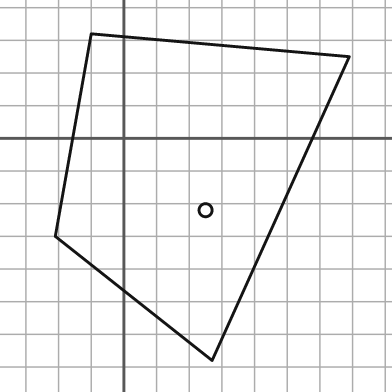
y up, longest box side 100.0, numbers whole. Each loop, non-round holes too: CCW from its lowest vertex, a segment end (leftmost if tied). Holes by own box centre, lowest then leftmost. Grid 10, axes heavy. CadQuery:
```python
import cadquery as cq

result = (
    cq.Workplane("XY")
    .moveTo(27.0, -68.0)
    .lineTo(69.0, 25.0)
    .lineTo(-10.0, 32.0)
    .lineTo(-21.0, -30.0)
    .close()
    .moveTo(25.0, -22.0)
    .circle(2.0)
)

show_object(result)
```